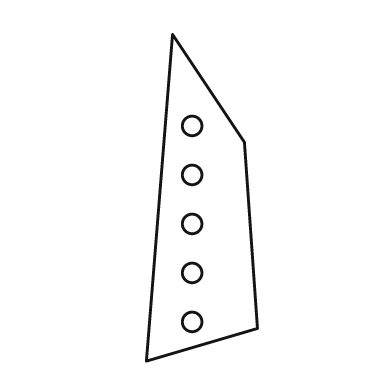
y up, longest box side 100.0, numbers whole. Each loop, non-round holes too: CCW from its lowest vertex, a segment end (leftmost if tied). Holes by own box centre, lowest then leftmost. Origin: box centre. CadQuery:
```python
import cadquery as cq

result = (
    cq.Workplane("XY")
    .moveTo(-17.0, -50.0)
    .lineTo(17.0, -40.0)
    .lineTo(13.0, 17.0)
    .lineTo(-9.0, 50.0)
    .close()
    .moveTo(-3.0, -38.0)
    .circle(3.0)
    .moveTo(-3.0, -23.0)
    .circle(3.0)
    .moveTo(-3.0, -8.0)
    .circle(3.0)
    .moveTo(-3.0, 7.0)
    .circle(3.0)
    .moveTo(-3.0, 22.0)
    .circle(3.0)
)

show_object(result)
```